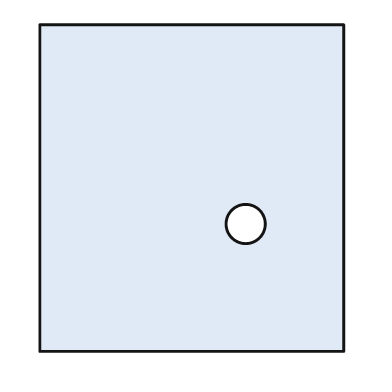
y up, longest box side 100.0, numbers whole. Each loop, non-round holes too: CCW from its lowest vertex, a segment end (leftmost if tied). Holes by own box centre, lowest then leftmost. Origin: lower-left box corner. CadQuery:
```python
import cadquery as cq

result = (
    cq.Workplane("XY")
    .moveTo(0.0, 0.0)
    .lineTo(93.0, 0.0)
    .lineTo(93.0, 100.0)
    .lineTo(0.0, 100.0)
    .close()
    .moveTo(63.0, 39.0)
    .circle(6.0)
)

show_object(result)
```